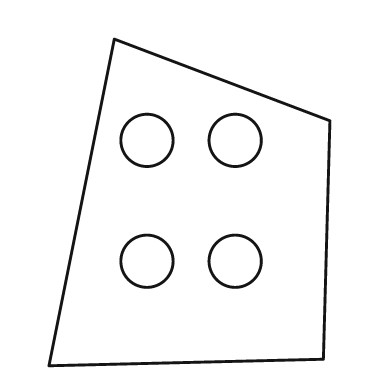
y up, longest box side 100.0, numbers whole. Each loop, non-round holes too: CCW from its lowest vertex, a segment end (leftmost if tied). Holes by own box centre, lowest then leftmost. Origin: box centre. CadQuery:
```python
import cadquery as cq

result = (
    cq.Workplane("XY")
    .moveTo(-43.0, -50.0)
    .lineTo(41.0, -48.0)
    .lineTo(43.0, 25.0)
    .lineTo(-23.0, 50.0)
    .close()
    .moveTo(-13.0, -18.0)
    .circle(8.0)
    .moveTo(14.0, -18.0)
    .circle(8.0)
    .moveTo(-13.0, 19.0)
    .circle(8.0)
    .moveTo(14.0, 19.0)
    .circle(8.0)
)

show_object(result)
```